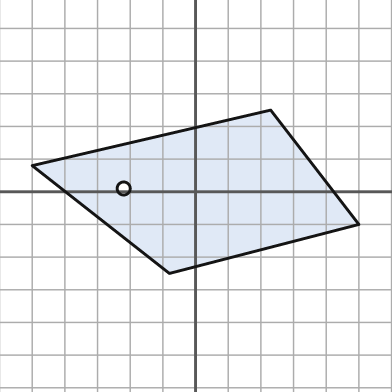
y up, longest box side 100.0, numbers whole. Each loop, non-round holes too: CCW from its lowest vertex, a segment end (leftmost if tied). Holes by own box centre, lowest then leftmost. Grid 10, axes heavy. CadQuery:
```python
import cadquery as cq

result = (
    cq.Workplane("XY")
    .moveTo(-8.0, -25.0)
    .lineTo(50.0, -10.0)
    .lineTo(23.0, 25.0)
    .lineTo(-50.0, 8.0)
    .close()
    .moveTo(-22.0, 1.0)
    .circle(2.0)
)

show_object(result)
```